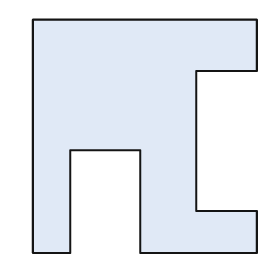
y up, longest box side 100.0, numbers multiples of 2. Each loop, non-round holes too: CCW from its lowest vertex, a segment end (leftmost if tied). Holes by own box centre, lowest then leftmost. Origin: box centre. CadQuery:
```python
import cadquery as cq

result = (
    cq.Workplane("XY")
    .moveTo(-48.0, -50.0)
    .lineTo(-32.0, -50.0)
    .lineTo(-32.0, -6.0)
    .lineTo(-2.0, -6.0)
    .lineTo(-2.0, -50.0)
    .lineTo(48.0, -50.0)
    .lineTo(48.0, -32.0)
    .lineTo(22.0, -32.0)
    .lineTo(22.0, 28.0)
    .lineTo(48.0, 28.0)
    .lineTo(48.0, 50.0)
    .lineTo(-48.0, 50.0)
    .close()
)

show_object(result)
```